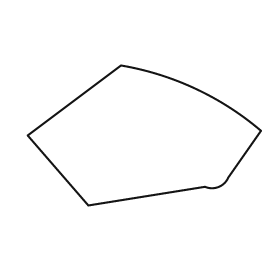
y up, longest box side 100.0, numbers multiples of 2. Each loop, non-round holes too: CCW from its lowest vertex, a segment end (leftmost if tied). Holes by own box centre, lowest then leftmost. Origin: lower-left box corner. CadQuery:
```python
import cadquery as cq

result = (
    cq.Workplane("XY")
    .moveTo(26.0, 0.0)
    .lineTo(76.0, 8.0)
    .threePointArc((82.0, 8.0), (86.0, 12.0))
    .lineTo(100.0, 32.0)
    .threePointArc((72.0, 50.0), (40.0, 60.0))
    .lineTo(0.0, 30.0)
    .close()
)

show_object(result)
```